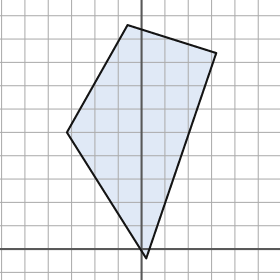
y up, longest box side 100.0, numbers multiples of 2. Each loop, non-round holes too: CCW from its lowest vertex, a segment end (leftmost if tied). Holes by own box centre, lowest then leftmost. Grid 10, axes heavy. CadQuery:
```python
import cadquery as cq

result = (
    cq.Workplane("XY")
    .moveTo(2.0, -4.0)
    .lineTo(32.0, 84.0)
    .lineTo(-6.0, 96.0)
    .lineTo(-32.0, 50.0)
    .close()
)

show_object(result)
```